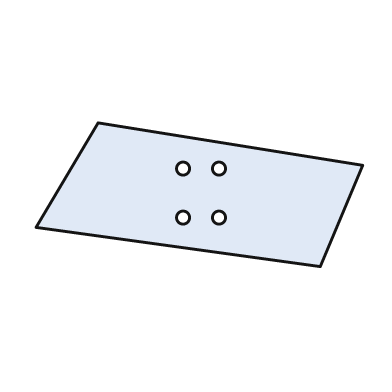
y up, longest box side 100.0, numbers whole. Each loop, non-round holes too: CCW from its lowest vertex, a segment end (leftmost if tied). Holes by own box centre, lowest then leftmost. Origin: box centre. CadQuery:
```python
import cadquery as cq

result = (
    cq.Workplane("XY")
    .moveTo(37.0, -22.0)
    .lineTo(50.0, 9.0)
    .lineTo(-31.0, 22.0)
    .lineTo(-50.0, -10.0)
    .close()
    .moveTo(-5.0, -7.0)
    .circle(2.0)
    .moveTo(6.0, -7.0)
    .circle(2.0)
    .moveTo(-5.0, 8.0)
    .circle(2.0)
    .moveTo(6.0, 8.0)
    .circle(2.0)
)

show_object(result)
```